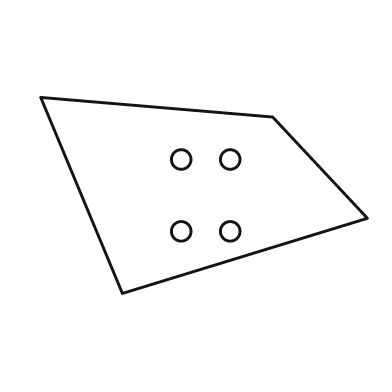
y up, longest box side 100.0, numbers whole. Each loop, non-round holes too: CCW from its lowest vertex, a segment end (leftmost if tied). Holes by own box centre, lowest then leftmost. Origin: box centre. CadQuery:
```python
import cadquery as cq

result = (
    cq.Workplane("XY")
    .moveTo(-25.0, -30.0)
    .lineTo(50.0, -7.0)
    .lineTo(21.0, 24.0)
    .lineTo(-50.0, 30.0)
    .close()
    .moveTo(-7.0, -11.0)
    .circle(3.0)
    .moveTo(8.0, -11.0)
    .circle(3.0)
    .moveTo(-7.0, 11.0)
    .circle(3.0)
    .moveTo(8.0, 11.0)
    .circle(3.0)
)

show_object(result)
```